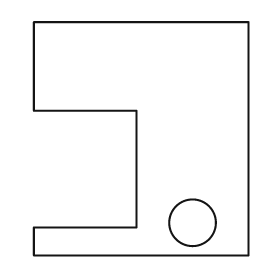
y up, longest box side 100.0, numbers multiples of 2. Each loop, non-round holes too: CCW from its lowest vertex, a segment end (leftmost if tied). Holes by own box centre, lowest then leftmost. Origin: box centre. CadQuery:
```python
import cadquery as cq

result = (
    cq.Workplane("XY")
    .moveTo(-46.0, -50.0)
    .lineTo(46.0, -50.0)
    .lineTo(46.0, 50.0)
    .lineTo(-46.0, 50.0)
    .lineTo(-46.0, 12.0)
    .lineTo(-2.0, 12.0)
    .lineTo(-2.0, -38.0)
    .lineTo(-46.0, -38.0)
    .close()
    .moveTo(22.0, -36.0)
    .circle(10.0)
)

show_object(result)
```